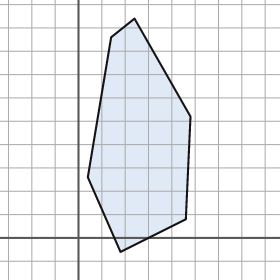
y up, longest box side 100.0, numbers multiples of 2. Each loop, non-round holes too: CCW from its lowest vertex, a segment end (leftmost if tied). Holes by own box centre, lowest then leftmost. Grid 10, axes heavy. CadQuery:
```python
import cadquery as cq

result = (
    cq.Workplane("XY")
    .moveTo(18.0, -6.0)
    .lineTo(46.0, 8.0)
    .lineTo(48.0, 52.0)
    .lineTo(24.0, 94.0)
    .lineTo(14.0, 86.0)
    .lineTo(4.0, 26.0)
    .close()
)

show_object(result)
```